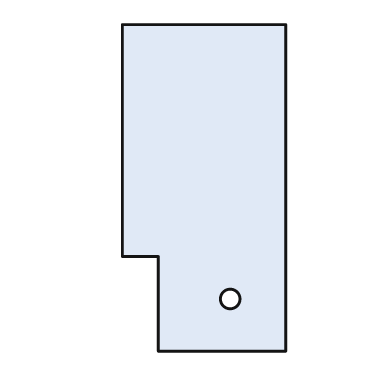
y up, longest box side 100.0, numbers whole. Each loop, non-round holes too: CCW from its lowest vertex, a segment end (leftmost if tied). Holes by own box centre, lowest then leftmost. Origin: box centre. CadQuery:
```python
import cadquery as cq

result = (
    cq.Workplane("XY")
    .moveTo(-14.0, -50.0)
    .lineTo(25.0, -50.0)
    .lineTo(25.0, 50.0)
    .lineTo(-25.0, 50.0)
    .lineTo(-25.0, -21.0)
    .lineTo(-14.0, -21.0)
    .close()
    .moveTo(8.0, -34.0)
    .circle(3.0)
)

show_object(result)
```